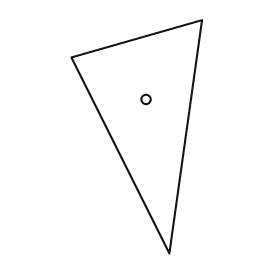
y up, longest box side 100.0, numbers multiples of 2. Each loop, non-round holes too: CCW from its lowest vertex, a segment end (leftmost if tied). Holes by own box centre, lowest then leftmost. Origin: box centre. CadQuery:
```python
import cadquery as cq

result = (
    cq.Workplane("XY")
    .moveTo(14.0, -50.0)
    .lineTo(28.0, 50.0)
    .lineTo(-28.0, 34.0)
    .close()
    .moveTo(4.0, 16.0)
    .circle(2.0)
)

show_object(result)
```